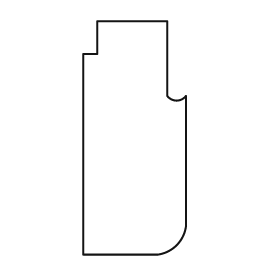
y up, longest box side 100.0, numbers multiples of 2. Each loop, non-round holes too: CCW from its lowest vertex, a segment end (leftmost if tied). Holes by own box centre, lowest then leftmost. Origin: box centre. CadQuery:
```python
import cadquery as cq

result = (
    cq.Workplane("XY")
    .moveTo(-22.0, -50.0)
    .lineTo(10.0, -50.0)
    .threePointArc((18.0, -46.0), (22.0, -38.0))
    .lineTo(22.0, 18.0)
    .threePointArc((18.0, 16.0), (14.0, 18.0))
    .lineTo(14.0, 50.0)
    .lineTo(-16.0, 50.0)
    .lineTo(-16.0, 36.0)
    .lineTo(-22.0, 36.0)
    .close()
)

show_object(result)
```